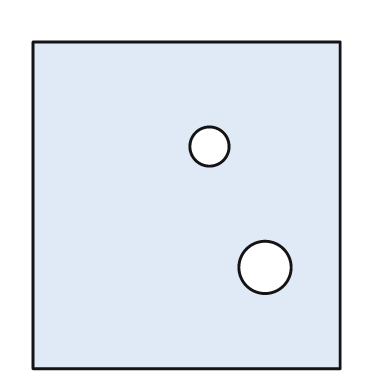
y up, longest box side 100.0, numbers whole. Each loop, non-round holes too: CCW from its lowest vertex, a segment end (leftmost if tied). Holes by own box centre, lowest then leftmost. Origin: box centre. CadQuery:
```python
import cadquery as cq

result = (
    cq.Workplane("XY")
    .moveTo(-47.0, -50.0)
    .lineTo(47.0, -50.0)
    .lineTo(47.0, 50.0)
    .lineTo(-47.0, 50.0)
    .close()
    .moveTo(24.0, -19.0)
    .circle(8.0)
    .moveTo(7.0, 18.0)
    .circle(6.0)
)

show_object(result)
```